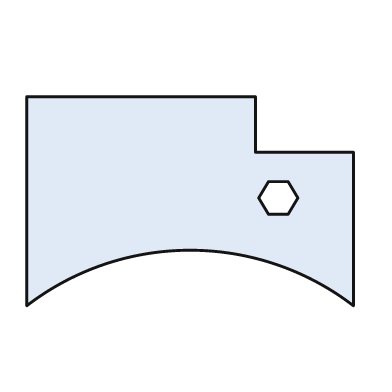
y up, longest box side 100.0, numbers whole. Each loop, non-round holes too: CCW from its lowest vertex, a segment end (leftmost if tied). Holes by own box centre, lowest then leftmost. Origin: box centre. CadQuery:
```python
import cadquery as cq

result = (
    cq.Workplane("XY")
    .moveTo(-50.0, -32.0)
    .threePointArc((0.0, -15.0), (50.0, -32.0))
    .lineTo(50.0, 15.0)
    .lineTo(20.0, 15.0)
    .lineTo(20.0, 32.0)
    .lineTo(-50.0, 32.0)
    .close()
    .moveTo(24.0, -4.0)
    .lineTo(30.0, -4.0)
    .lineTo(33.0, 1.0)
    .lineTo(30.0, 6.0)
    .lineTo(24.0, 6.0)
    .lineTo(21.0, 1.0)
    .close()
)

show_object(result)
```